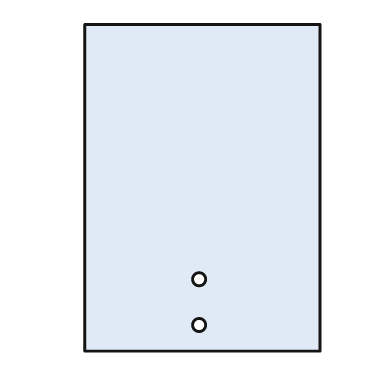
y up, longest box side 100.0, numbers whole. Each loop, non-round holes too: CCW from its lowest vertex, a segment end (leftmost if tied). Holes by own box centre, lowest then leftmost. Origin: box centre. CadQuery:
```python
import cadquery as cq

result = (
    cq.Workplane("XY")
    .moveTo(-36.0, -50.0)
    .lineTo(36.0, -50.0)
    .lineTo(36.0, 50.0)
    .lineTo(-36.0, 50.0)
    .close()
    .moveTo(-1.0, -42.0)
    .circle(2.0)
    .moveTo(-1.0, -28.0)
    .circle(2.0)
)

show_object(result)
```